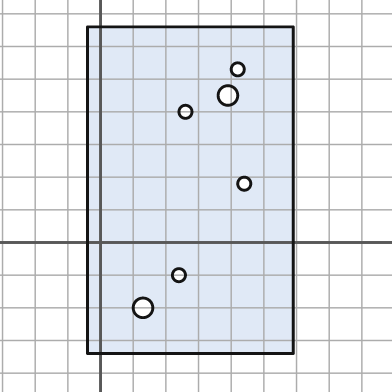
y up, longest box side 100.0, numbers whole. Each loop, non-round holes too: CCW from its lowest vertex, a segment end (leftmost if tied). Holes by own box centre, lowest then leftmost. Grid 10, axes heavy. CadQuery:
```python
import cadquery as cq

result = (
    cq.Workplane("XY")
    .moveTo(-4.0, -34.0)
    .lineTo(59.0, -34.0)
    .lineTo(59.0, 66.0)
    .lineTo(-4.0, 66.0)
    .close()
    .moveTo(13.0, -20.0)
    .circle(3.0)
    .moveTo(24.0, -10.0)
    .circle(2.0)
    .moveTo(44.0, 18.0)
    .circle(2.0)
    .moveTo(26.0, 40.0)
    .circle(2.0)
    .moveTo(39.0, 45.0)
    .circle(3.0)
    .moveTo(42.0, 53.0)
    .circle(2.0)
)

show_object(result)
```